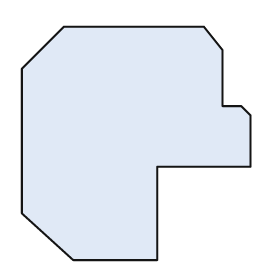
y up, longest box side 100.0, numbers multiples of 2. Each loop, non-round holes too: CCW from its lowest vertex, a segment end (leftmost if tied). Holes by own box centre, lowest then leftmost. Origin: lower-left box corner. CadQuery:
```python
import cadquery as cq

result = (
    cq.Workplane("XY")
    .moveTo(22.0, 0.0)
    .lineTo(58.0, 0.0)
    .lineTo(58.0, 40.0)
    .lineTo(98.0, 40.0)
    .lineTo(98.0, 62.0)
    .lineTo(94.0, 66.0)
    .lineTo(86.0, 66.0)
    .lineTo(86.0, 90.0)
    .lineTo(78.0, 100.0)
    .lineTo(18.0, 100.0)
    .lineTo(0.0, 82.0)
    .lineTo(0.0, 20.0)
    .close()
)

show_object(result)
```